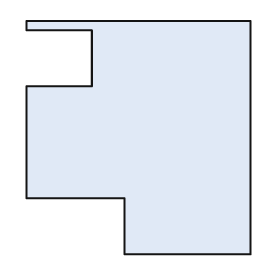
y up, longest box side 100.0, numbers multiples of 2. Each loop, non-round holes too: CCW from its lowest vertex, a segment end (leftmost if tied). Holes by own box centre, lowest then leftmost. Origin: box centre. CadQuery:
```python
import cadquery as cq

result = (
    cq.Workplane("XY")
    .moveTo(-6.0, -50.0)
    .lineTo(48.0, -50.0)
    .lineTo(48.0, 50.0)
    .lineTo(-48.0, 50.0)
    .lineTo(-48.0, 46.0)
    .lineTo(-20.0, 46.0)
    .lineTo(-20.0, 22.0)
    .lineTo(-48.0, 22.0)
    .lineTo(-48.0, -26.0)
    .lineTo(-6.0, -26.0)
    .close()
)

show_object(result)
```